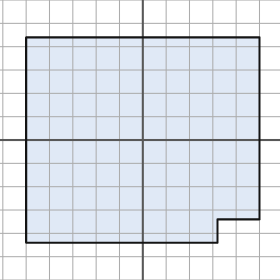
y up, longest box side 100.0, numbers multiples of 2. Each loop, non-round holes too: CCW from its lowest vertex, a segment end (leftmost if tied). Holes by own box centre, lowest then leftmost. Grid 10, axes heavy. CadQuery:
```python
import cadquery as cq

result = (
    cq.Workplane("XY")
    .moveTo(-50.0, -44.0)
    .lineTo(32.0, -44.0)
    .lineTo(32.0, -34.0)
    .lineTo(50.0, -34.0)
    .lineTo(50.0, 44.0)
    .lineTo(-50.0, 44.0)
    .close()
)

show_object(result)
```